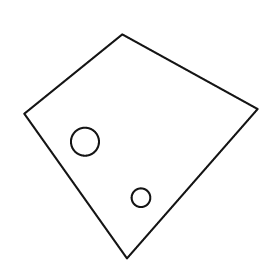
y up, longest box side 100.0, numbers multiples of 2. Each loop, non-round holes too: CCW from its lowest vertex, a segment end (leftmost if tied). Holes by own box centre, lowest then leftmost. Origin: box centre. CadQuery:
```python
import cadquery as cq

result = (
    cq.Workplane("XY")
    .moveTo(-6.0, -48.0)
    .lineTo(50.0, 16.0)
    .lineTo(-8.0, 48.0)
    .lineTo(-50.0, 14.0)
    .close()
    .moveTo(0.0, -22.0)
    .circle(4.0)
    .moveTo(-24.0, 2.0)
    .circle(6.0)
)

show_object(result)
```